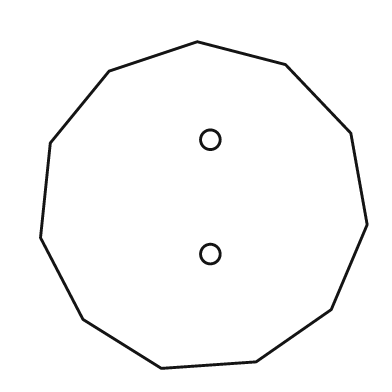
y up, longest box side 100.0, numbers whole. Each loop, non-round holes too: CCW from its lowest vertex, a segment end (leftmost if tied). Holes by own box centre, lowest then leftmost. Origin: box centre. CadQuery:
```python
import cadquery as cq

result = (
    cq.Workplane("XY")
    .moveTo(-13.0, -50.0)
    .lineTo(16.0, -48.0)
    .lineTo(39.0, -32.0)
    .lineTo(50.0, -6.0)
    .lineTo(45.0, 22.0)
    .lineTo(25.0, 43.0)
    .lineTo(-2.0, 50.0)
    .lineTo(-29.0, 41.0)
    .lineTo(-47.0, 19.0)
    .lineTo(-50.0, -10.0)
    .lineTo(-37.0, -35.0)
    .close()
    .moveTo(2.0, -15.0)
    .circle(3.0)
    .moveTo(2.0, 20.0)
    .circle(3.0)
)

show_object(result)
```